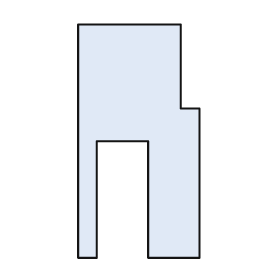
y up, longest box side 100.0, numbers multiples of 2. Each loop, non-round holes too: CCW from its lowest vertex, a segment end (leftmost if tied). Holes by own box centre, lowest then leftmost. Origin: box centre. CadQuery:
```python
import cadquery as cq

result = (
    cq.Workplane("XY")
    .moveTo(-26.0, -50.0)
    .lineTo(-18.0, -50.0)
    .lineTo(-18.0, 0.0)
    .lineTo(4.0, 0.0)
    .lineTo(4.0, -50.0)
    .lineTo(26.0, -50.0)
    .lineTo(26.0, 14.0)
    .lineTo(18.0, 14.0)
    .lineTo(18.0, 50.0)
    .lineTo(-26.0, 50.0)
    .close()
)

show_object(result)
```